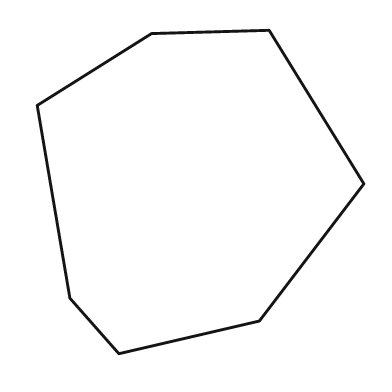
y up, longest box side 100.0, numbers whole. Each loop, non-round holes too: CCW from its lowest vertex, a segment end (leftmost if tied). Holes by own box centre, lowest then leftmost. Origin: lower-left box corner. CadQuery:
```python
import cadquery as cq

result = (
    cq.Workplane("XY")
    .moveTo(25.0, 0.0)
    .lineTo(68.0, 10.0)
    .lineTo(100.0, 52.0)
    .lineTo(71.0, 99.0)
    .lineTo(35.0, 98.0)
    .lineTo(0.0, 76.0)
    .lineTo(10.0, 17.0)
    .close()
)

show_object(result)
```